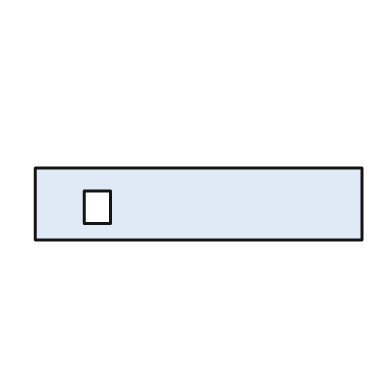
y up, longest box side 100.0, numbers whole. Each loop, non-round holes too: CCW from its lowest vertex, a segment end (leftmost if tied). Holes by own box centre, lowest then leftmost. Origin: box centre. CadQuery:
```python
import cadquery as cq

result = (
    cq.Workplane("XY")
    .moveTo(-50.0, -11.0)
    .lineTo(50.0, -11.0)
    .lineTo(50.0, 11.0)
    .lineTo(-50.0, 11.0)
    .close()
    .moveTo(-35.0, -6.0)
    .lineTo(-27.0, -6.0)
    .lineTo(-27.0, 4.0)
    .lineTo(-35.0, 4.0)
    .close()
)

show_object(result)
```